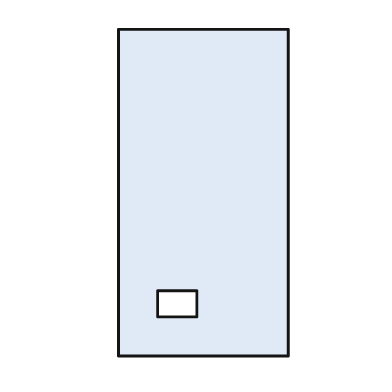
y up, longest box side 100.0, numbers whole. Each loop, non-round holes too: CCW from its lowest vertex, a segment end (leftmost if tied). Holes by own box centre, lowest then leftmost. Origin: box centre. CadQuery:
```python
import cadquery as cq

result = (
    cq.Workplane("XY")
    .moveTo(-26.0, -50.0)
    .lineTo(26.0, -50.0)
    .lineTo(26.0, 50.0)
    .lineTo(-26.0, 50.0)
    .close()
    .moveTo(-14.0, -38.0)
    .lineTo(-2.0, -38.0)
    .lineTo(-2.0, -30.0)
    .lineTo(-14.0, -30.0)
    .close()
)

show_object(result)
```